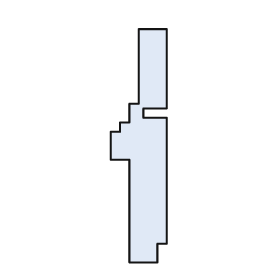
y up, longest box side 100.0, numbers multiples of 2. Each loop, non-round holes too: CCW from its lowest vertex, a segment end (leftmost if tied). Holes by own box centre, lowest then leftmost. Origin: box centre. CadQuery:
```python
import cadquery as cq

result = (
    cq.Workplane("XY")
    .moveTo(-4.0, -50.0)
    .lineTo(8.0, -50.0)
    .lineTo(8.0, -42.0)
    .lineTo(12.0, -42.0)
    .lineTo(12.0, 12.0)
    .lineTo(2.0, 12.0)
    .lineTo(2.0, 16.0)
    .lineTo(12.0, 16.0)
    .lineTo(12.0, 50.0)
    .lineTo(0.0, 50.0)
    .lineTo(0.0, 18.0)
    .lineTo(-4.0, 18.0)
    .lineTo(-4.0, 10.0)
    .lineTo(-8.0, 10.0)
    .lineTo(-8.0, 6.0)
    .lineTo(-12.0, 6.0)
    .lineTo(-12.0, -6.0)
    .lineTo(-4.0, -6.0)
    .close()
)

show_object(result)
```